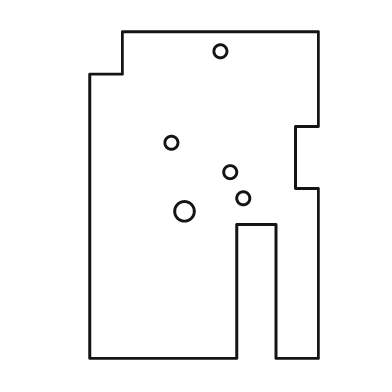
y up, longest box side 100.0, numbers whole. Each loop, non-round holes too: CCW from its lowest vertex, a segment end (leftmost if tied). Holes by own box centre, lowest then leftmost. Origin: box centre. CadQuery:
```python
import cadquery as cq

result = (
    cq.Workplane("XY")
    .moveTo(-35.0, -50.0)
    .lineTo(10.0, -50.0)
    .lineTo(10.0, -9.0)
    .lineTo(22.0, -9.0)
    .lineTo(22.0, -50.0)
    .lineTo(35.0, -50.0)
    .lineTo(35.0, 2.0)
    .lineTo(28.0, 2.0)
    .lineTo(28.0, 21.0)
    .lineTo(35.0, 21.0)
    .lineTo(35.0, 50.0)
    .lineTo(-25.0, 50.0)
    .lineTo(-25.0, 37.0)
    .lineTo(-35.0, 37.0)
    .close()
    .moveTo(-6.0, -5.0)
    .circle(3.0)
    .moveTo(12.0, -1.0)
    .circle(2.0)
    .moveTo(8.0, 7.0)
    .circle(2.0)
    .moveTo(-10.0, 16.0)
    .circle(2.0)
    .moveTo(5.0, 44.0)
    .circle(2.0)
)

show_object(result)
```